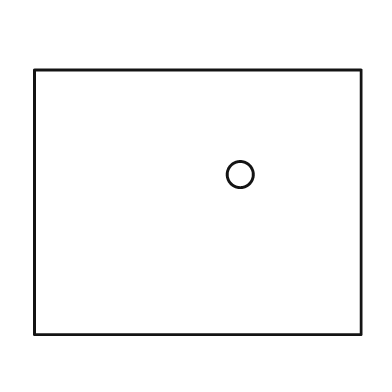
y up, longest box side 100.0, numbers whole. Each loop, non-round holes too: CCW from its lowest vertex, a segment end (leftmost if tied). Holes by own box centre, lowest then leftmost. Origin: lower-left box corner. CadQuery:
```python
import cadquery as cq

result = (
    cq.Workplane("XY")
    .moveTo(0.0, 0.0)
    .lineTo(100.0, 0.0)
    .lineTo(100.0, 81.0)
    .lineTo(0.0, 81.0)
    .close()
    .moveTo(63.0, 49.0)
    .circle(4.0)
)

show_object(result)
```